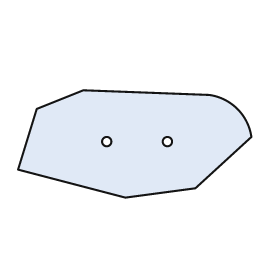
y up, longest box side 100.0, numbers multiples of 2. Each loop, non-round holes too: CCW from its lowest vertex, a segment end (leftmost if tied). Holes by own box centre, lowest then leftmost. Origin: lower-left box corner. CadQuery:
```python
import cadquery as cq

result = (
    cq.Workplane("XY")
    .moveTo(46.0, 0.0)
    .lineTo(76.0, 4.0)
    .lineTo(100.0, 26.0)
    .threePointArc((94.0, 38.0), (82.0, 44.0))
    .lineTo(28.0, 46.0)
    .lineTo(8.0, 38.0)
    .lineTo(0.0, 12.0)
    .close()
    .moveTo(38.0, 24.0)
    .circle(2.0)
    .moveTo(64.0, 24.0)
    .circle(2.0)
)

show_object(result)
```